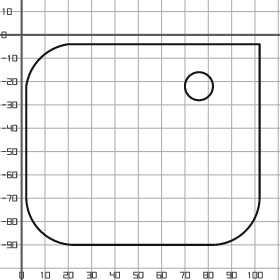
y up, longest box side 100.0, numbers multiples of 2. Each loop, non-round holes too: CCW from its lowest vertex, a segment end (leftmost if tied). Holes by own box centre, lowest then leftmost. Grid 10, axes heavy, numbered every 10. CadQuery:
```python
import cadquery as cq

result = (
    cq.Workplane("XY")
    .moveTo(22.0, -90.0)
    .lineTo(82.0, -90.0)
    .threePointArc((96.0, -84.0), (102.0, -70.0))
    .lineTo(102.0, -4.0)
    .lineTo(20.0, -4.0)
    .threePointArc((8.0, -10.0), (2.0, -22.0))
    .lineTo(2.0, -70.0)
    .threePointArc((8.0, -84.0), (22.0, -90.0))
    .close()
    .moveTo(76.0, -22.0)
    .circle(6.0)
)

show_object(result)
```